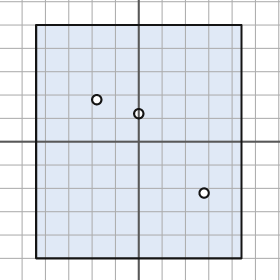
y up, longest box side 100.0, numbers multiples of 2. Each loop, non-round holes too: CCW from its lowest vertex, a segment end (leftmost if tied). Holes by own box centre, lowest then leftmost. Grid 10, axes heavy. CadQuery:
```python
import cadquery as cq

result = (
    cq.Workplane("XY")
    .moveTo(-44.0, -50.0)
    .lineTo(44.0, -50.0)
    .lineTo(44.0, 50.0)
    .lineTo(-44.0, 50.0)
    .close()
    .moveTo(28.0, -22.0)
    .circle(2.0)
    .moveTo(0.0, 12.0)
    .circle(2.0)
    .moveTo(-18.0, 18.0)
    .circle(2.0)
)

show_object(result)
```